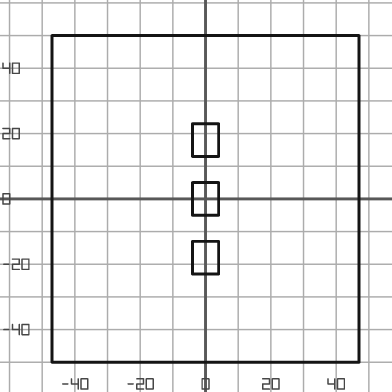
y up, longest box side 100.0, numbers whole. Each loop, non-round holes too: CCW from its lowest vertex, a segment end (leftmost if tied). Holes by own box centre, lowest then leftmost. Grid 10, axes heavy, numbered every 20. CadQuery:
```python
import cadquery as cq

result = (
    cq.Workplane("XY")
    .moveTo(-47.0, -50.0)
    .lineTo(47.0, -50.0)
    .lineTo(47.0, 50.0)
    .lineTo(-47.0, 50.0)
    .close()
    .moveTo(-4.0, -23.0)
    .lineTo(4.0, -23.0)
    .lineTo(4.0, -13.0)
    .lineTo(-4.0, -13.0)
    .close()
    .moveTo(-4.0, -5.0)
    .lineTo(4.0, -5.0)
    .lineTo(4.0, 5.0)
    .lineTo(-4.0, 5.0)
    .close()
    .moveTo(-4.0, 13.0)
    .lineTo(4.0, 13.0)
    .lineTo(4.0, 23.0)
    .lineTo(-4.0, 23.0)
    .close()
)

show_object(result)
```